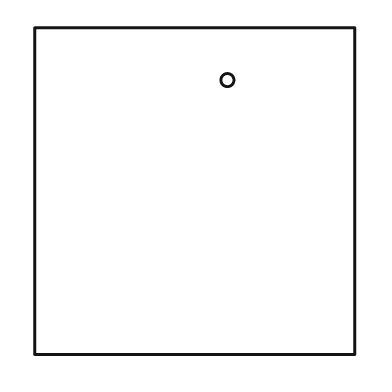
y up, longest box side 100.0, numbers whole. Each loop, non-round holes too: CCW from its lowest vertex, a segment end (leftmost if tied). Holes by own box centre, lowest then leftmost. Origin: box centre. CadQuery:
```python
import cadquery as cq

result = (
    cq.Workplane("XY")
    .moveTo(-49.0, -50.0)
    .lineTo(49.0, -50.0)
    .lineTo(49.0, 50.0)
    .lineTo(-49.0, 50.0)
    .close()
    .moveTo(10.0, 34.0)
    .circle(2.0)
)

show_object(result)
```